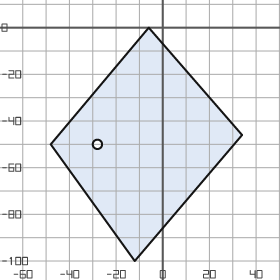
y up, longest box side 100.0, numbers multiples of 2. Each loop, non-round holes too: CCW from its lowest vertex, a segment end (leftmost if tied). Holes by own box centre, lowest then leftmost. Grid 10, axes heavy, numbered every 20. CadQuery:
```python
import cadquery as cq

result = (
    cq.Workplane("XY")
    .moveTo(-12.0, -100.0)
    .lineTo(34.0, -46.0)
    .lineTo(-6.0, 0.0)
    .lineTo(-48.0, -50.0)
    .close()
    .moveTo(-28.0, -50.0)
    .circle(2.0)
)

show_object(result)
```